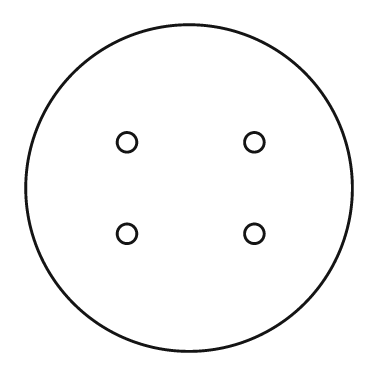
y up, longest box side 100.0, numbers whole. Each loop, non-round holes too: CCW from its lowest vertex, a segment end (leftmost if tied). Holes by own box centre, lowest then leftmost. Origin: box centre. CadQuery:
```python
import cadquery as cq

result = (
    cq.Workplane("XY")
    .moveTo(0.0, 0.0)
    .circle(50.0)
    .moveTo(-19.0, -14.0)
    .circle(3.0)
    .moveTo(20.0, -14.0)
    .circle(3.0)
    .moveTo(-19.0, 14.0)
    .circle(3.0)
    .moveTo(20.0, 14.0)
    .circle(3.0)
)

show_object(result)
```